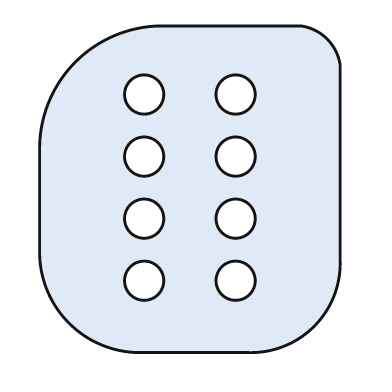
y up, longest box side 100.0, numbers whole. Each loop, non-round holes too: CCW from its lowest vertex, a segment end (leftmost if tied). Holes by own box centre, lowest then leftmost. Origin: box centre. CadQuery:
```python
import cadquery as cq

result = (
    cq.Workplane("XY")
    .moveTo(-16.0, -50.0)
    .lineTo(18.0, -50.0)
    .threePointArc((38.0, -42.0), (46.0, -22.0))
    .lineTo(46.0, 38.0)
    .threePointArc((42.0, 46.0), (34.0, 50.0))
    .lineTo(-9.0, 50.0)
    .threePointArc((-35.0, 39.0), (-46.0, 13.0))
    .lineTo(-46.0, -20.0)
    .threePointArc((-37.0, -41.0), (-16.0, -50.0))
    .close()
    .moveTo(-14.0, -28.0)
    .circle(6.0)
    .moveTo(14.0, -28.0)
    .circle(6.0)
    .moveTo(-14.0, -9.0)
    .circle(6.0)
    .moveTo(14.0, -9.0)
    .circle(6.0)
    .moveTo(-14.0, 10.0)
    .circle(6.0)
    .moveTo(14.0, 10.0)
    .circle(6.0)
    .moveTo(-14.0, 29.0)
    .circle(6.0)
    .moveTo(14.0, 29.0)
    .circle(6.0)
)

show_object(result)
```